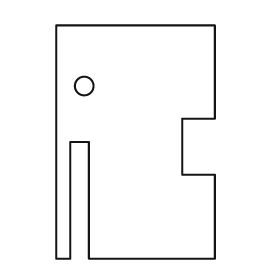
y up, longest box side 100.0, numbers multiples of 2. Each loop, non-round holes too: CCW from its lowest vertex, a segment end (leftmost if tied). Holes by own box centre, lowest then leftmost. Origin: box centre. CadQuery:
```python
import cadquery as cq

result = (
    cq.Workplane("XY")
    .moveTo(-34.0, -50.0)
    .lineTo(-28.0, -50.0)
    .lineTo(-28.0, 0.0)
    .lineTo(-20.0, 0.0)
    .lineTo(-20.0, -50.0)
    .lineTo(34.0, -50.0)
    .lineTo(34.0, -14.0)
    .lineTo(20.0, -14.0)
    .lineTo(20.0, 10.0)
    .lineTo(34.0, 10.0)
    .lineTo(34.0, 50.0)
    .lineTo(-34.0, 50.0)
    .close()
    .moveTo(-22.0, 24.0)
    .circle(4.0)
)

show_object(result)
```